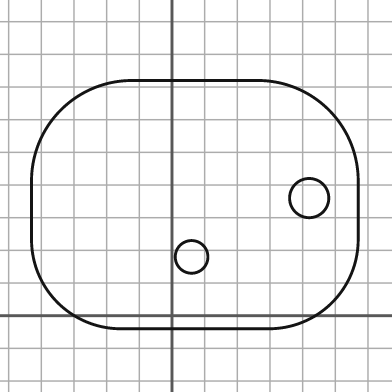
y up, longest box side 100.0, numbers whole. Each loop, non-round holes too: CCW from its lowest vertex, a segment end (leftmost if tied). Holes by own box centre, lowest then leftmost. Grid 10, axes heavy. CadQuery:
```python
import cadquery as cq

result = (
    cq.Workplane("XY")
    .moveTo(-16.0, -4.0)
    .lineTo(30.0, -4.0)
    .threePointArc((49.0, 4.0), (57.0, 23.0))
    .lineTo(57.0, 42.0)
    .threePointArc((48.0, 63.0), (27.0, 72.0))
    .lineTo(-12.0, 72.0)
    .threePointArc((-34.0, 63.0), (-43.0, 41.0))
    .lineTo(-43.0, 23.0)
    .threePointArc((-35.0, 4.0), (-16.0, -4.0))
    .close()
    .moveTo(6.0, 18.0)
    .circle(5.0)
    .moveTo(42.0, 36.0)
    .circle(6.0)
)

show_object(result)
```